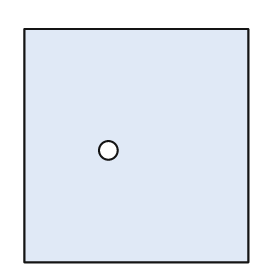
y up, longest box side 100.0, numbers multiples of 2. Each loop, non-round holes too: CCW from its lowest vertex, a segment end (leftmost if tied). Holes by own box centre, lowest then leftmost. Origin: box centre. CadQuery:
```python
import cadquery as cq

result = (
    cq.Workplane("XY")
    .moveTo(-48.0, -50.0)
    .lineTo(48.0, -50.0)
    .lineTo(48.0, 50.0)
    .lineTo(-48.0, 50.0)
    .close()
    .moveTo(-12.0, -2.0)
    .circle(4.0)
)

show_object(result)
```